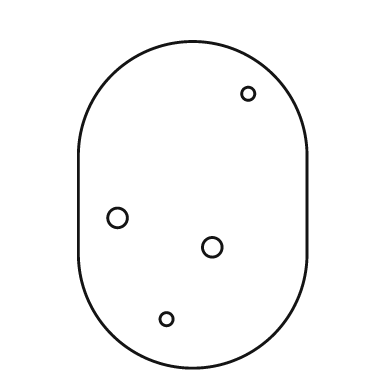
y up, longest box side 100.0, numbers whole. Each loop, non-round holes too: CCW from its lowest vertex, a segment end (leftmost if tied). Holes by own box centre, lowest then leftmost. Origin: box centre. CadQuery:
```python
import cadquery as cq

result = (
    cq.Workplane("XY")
    .moveTo(-35.0, -15.0)
    .threePointArc((0.0, -50.0), (35.0, -15.0))
    .lineTo(35.0, 15.0)
    .threePointArc((0.0, 50.0), (-35.0, 15.0))
    .close()
    .moveTo(-8.0, -35.0)
    .circle(2.0)
    .moveTo(6.0, -13.0)
    .circle(3.0)
    .moveTo(-23.0, -4.0)
    .circle(3.0)
    .moveTo(17.0, 34.0)
    .circle(2.0)
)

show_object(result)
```